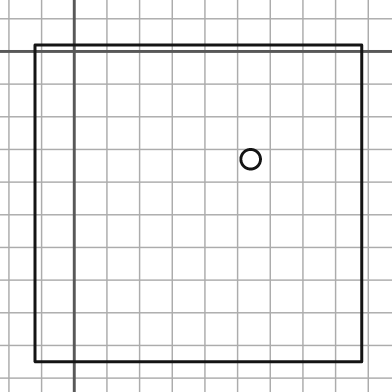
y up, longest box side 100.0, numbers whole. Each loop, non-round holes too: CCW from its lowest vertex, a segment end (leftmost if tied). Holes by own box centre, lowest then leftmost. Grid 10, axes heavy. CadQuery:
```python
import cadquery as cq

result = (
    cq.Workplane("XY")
    .moveTo(-12.0, -95.0)
    .lineTo(88.0, -95.0)
    .lineTo(88.0, 2.0)
    .lineTo(-12.0, 2.0)
    .close()
    .moveTo(54.0, -33.0)
    .circle(3.0)
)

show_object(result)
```